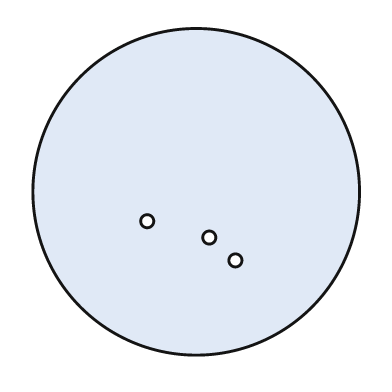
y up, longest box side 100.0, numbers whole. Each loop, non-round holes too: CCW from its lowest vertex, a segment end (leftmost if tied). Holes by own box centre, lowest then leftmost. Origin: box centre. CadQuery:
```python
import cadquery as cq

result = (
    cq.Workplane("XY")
    .moveTo(0.0, 0.0)
    .circle(50.0)
    .moveTo(12.0, -21.0)
    .circle(2.0)
    .moveTo(4.0, -14.0)
    .circle(2.0)
    .moveTo(-15.0, -9.0)
    .circle(2.0)
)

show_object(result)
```